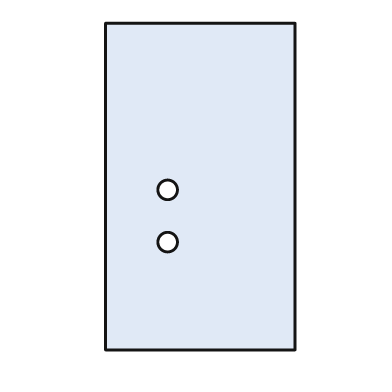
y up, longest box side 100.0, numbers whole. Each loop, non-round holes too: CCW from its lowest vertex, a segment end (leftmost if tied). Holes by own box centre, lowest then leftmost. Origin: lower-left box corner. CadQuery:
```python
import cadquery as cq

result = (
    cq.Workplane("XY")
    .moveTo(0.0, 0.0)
    .lineTo(58.0, 0.0)
    .lineTo(58.0, 100.0)
    .lineTo(0.0, 100.0)
    .close()
    .moveTo(19.0, 33.0)
    .circle(3.0)
    .moveTo(19.0, 49.0)
    .circle(3.0)
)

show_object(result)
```